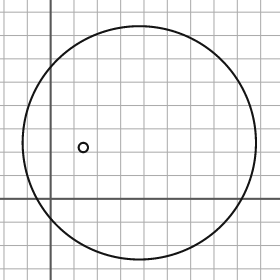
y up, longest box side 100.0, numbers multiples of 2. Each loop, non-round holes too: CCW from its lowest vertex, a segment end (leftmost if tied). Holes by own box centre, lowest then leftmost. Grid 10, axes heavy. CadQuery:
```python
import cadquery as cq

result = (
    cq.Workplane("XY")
    .moveTo(38.0, 24.0)
    .circle(50.0)
    .moveTo(14.0, 22.0)
    .circle(2.0)
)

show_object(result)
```